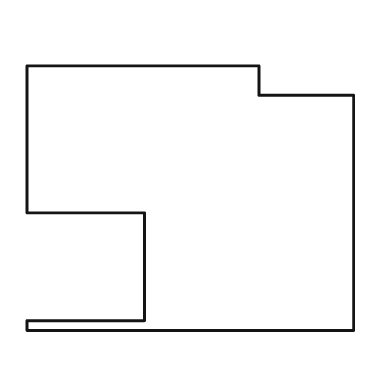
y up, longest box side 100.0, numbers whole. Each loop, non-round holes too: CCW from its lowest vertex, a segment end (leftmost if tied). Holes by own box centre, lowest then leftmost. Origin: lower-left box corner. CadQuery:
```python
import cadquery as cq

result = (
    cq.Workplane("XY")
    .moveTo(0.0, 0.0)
    .lineTo(100.0, 0.0)
    .lineTo(100.0, 72.0)
    .lineTo(71.0, 72.0)
    .lineTo(71.0, 81.0)
    .lineTo(0.0, 81.0)
    .lineTo(0.0, 36.0)
    .lineTo(36.0, 36.0)
    .lineTo(36.0, 3.0)
    .lineTo(0.0, 3.0)
    .close()
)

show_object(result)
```